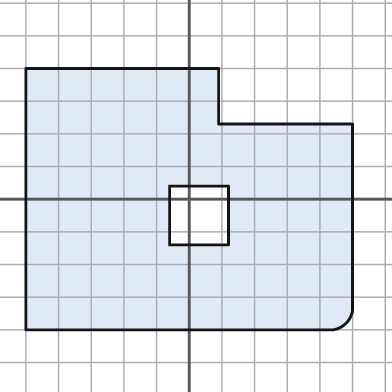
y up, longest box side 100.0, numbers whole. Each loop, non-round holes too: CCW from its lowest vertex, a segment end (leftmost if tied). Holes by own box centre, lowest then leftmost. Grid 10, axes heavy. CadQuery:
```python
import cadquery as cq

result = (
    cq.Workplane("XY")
    .moveTo(-50.0, -40.0)
    .lineTo(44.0, -40.0)
    .threePointArc((48.0, -38.0), (50.0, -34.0))
    .lineTo(50.0, 23.0)
    .lineTo(9.0, 23.0)
    .lineTo(9.0, 40.0)
    .lineTo(-50.0, 40.0)
    .close()
    .moveTo(-6.0, -14.0)
    .lineTo(12.0, -14.0)
    .lineTo(12.0, 4.0)
    .lineTo(-6.0, 4.0)
    .close()
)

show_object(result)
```